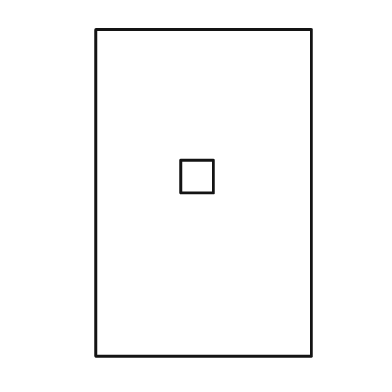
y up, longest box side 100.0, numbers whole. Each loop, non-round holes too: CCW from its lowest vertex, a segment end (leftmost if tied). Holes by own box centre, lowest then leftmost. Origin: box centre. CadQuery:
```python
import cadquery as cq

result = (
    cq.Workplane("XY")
    .moveTo(-33.0, -50.0)
    .lineTo(33.0, -50.0)
    .lineTo(33.0, 50.0)
    .lineTo(-33.0, 50.0)
    .close()
    .moveTo(-7.0, 0.0)
    .lineTo(3.0, 0.0)
    .lineTo(3.0, 10.0)
    .lineTo(-7.0, 10.0)
    .close()
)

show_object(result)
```